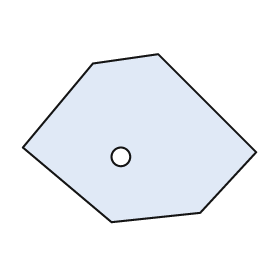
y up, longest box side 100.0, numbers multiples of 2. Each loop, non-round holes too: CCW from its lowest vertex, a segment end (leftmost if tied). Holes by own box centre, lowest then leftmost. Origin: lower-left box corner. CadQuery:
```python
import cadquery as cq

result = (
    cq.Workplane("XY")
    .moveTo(38.0, 0.0)
    .lineTo(76.0, 4.0)
    .lineTo(100.0, 30.0)
    .lineTo(58.0, 72.0)
    .lineTo(30.0, 68.0)
    .lineTo(0.0, 32.0)
    .close()
    .moveTo(42.0, 28.0)
    .circle(4.0)
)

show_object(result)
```